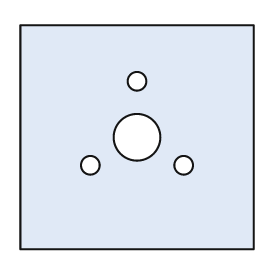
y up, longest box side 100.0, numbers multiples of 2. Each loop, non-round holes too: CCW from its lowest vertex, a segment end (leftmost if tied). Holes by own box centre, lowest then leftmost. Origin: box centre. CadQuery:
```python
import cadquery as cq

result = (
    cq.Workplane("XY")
    .moveTo(-50.0, -48.0)
    .lineTo(50.0, -48.0)
    .lineTo(50.0, 48.0)
    .lineTo(-50.0, 48.0)
    .close()
    .moveTo(-20.0, -12.0)
    .circle(4.0)
    .moveTo(20.0, -12.0)
    .circle(4.0)
    .moveTo(0.0, 0.0)
    .circle(10.0)
    .moveTo(0.0, 24.0)
    .circle(4.0)
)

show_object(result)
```